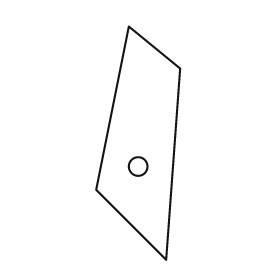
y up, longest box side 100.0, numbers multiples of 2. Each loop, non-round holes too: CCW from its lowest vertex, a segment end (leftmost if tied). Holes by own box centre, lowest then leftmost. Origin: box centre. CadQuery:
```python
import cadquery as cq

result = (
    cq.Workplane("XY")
    .moveTo(12.0, -50.0)
    .lineTo(18.0, 32.0)
    .lineTo(-4.0, 50.0)
    .lineTo(-18.0, -20.0)
    .close()
    .moveTo(0.0, -10.0)
    .circle(4.0)
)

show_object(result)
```